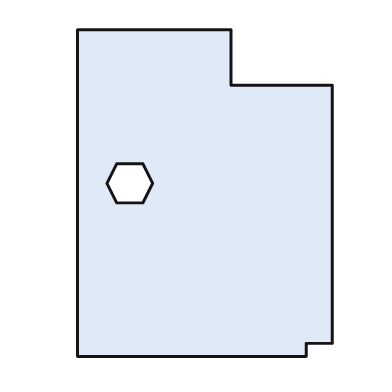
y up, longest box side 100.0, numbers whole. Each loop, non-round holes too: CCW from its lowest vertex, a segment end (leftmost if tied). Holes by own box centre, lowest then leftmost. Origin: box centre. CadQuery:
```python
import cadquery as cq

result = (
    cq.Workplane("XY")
    .moveTo(-39.0, -50.0)
    .lineTo(31.0, -50.0)
    .lineTo(31.0, -46.0)
    .lineTo(39.0, -46.0)
    .lineTo(39.0, 33.0)
    .lineTo(8.0, 33.0)
    .lineTo(8.0, 50.0)
    .lineTo(-39.0, 50.0)
    .close()
    .moveTo(-27.0, -3.0)
    .lineTo(-19.0, -3.0)
    .lineTo(-16.0, 3.0)
    .lineTo(-19.0, 9.0)
    .lineTo(-27.0, 9.0)
    .lineTo(-30.0, 3.0)
    .close()
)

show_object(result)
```